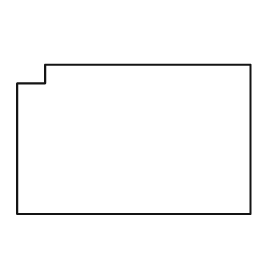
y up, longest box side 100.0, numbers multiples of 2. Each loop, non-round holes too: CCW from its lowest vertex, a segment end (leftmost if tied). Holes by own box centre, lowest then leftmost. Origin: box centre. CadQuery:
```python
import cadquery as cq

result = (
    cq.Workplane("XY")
    .moveTo(-50.0, -32.0)
    .lineTo(50.0, -32.0)
    .lineTo(50.0, 32.0)
    .lineTo(-38.0, 32.0)
    .lineTo(-38.0, 24.0)
    .lineTo(-50.0, 24.0)
    .close()
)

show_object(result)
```